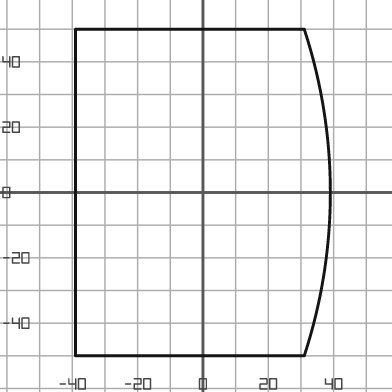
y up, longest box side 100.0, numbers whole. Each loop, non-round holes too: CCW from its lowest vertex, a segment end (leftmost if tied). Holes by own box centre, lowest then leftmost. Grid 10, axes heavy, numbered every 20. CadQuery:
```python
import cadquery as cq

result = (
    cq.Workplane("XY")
    .moveTo(-39.0, -50.0)
    .lineTo(31.0, -50.0)
    .threePointArc((39.0, 0.0), (31.0, 50.0))
    .lineTo(-39.0, 50.0)
    .close()
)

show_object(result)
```